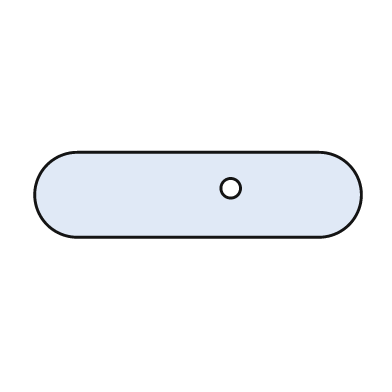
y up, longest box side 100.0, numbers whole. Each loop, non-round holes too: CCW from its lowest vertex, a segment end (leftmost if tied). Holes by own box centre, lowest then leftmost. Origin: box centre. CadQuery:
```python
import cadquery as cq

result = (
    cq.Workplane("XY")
    .moveTo(-37.0, -13.0)
    .lineTo(37.0, -13.0)
    .threePointArc((50.0, 0.0), (37.0, 13.0))
    .lineTo(-37.0, 13.0)
    .threePointArc((-50.0, 0.0), (-37.0, -13.0))
    .close()
    .moveTo(10.0, 2.0)
    .circle(3.0)
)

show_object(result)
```